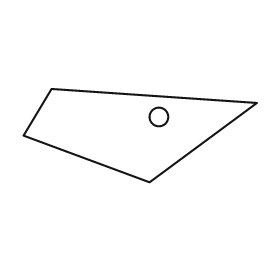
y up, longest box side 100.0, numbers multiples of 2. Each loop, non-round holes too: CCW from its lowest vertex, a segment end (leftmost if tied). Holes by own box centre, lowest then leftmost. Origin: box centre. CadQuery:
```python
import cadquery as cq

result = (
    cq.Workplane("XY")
    .moveTo(4.0, -20.0)
    .lineTo(50.0, 14.0)
    .lineTo(-38.0, 20.0)
    .lineTo(-50.0, 0.0)
    .close()
    .moveTo(8.0, 8.0)
    .circle(4.0)
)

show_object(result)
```